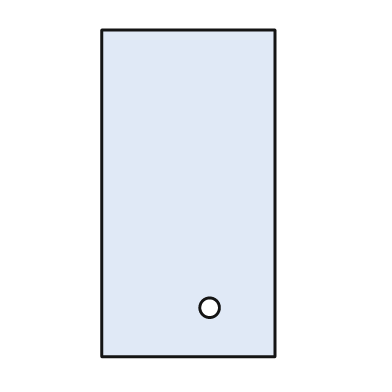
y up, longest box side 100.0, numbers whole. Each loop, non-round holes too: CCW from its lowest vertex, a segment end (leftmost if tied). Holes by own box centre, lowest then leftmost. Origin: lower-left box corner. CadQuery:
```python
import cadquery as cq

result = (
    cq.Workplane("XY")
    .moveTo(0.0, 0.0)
    .lineTo(53.0, 0.0)
    .lineTo(53.0, 100.0)
    .lineTo(0.0, 100.0)
    .close()
    .moveTo(33.0, 15.0)
    .circle(3.0)
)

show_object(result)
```